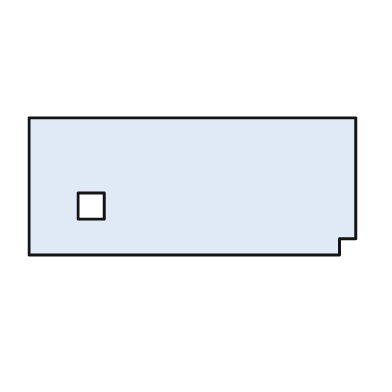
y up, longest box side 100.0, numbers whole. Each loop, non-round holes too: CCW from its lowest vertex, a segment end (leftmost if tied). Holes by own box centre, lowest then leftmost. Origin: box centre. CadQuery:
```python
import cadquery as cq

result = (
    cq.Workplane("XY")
    .moveTo(-50.0, -21.0)
    .lineTo(45.0, -21.0)
    .lineTo(45.0, -16.0)
    .lineTo(50.0, -16.0)
    .lineTo(50.0, 21.0)
    .lineTo(-50.0, 21.0)
    .close()
    .moveTo(-35.0, -10.0)
    .lineTo(-27.0, -10.0)
    .lineTo(-27.0, -2.0)
    .lineTo(-35.0, -2.0)
    .close()
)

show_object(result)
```